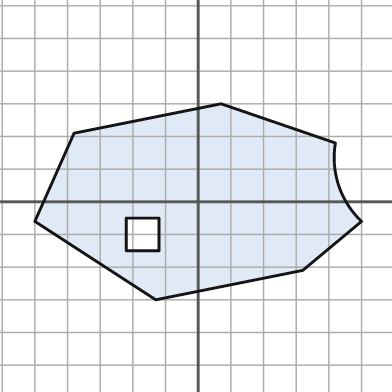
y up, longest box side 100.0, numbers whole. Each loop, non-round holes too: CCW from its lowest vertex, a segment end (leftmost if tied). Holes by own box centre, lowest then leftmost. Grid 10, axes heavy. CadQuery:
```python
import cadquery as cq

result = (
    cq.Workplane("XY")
    .moveTo(-13.0, -30.0)
    .lineTo(32.0, -21.0)
    .lineTo(50.0, -6.0)
    .threePointArc((43.0, 5.0), (42.0, 18.0))
    .lineTo(7.0, 30.0)
    .lineTo(-38.0, 21.0)
    .lineTo(-50.0, -6.0)
    .close()
    .moveTo(-22.0, -15.0)
    .lineTo(-12.0, -15.0)
    .lineTo(-12.0, -5.0)
    .lineTo(-22.0, -5.0)
    .close()
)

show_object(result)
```